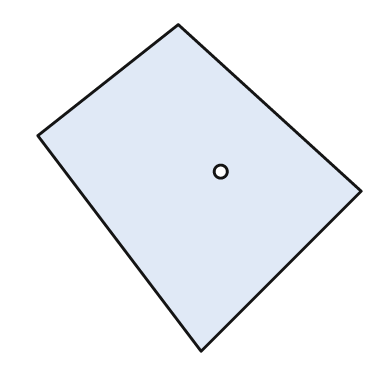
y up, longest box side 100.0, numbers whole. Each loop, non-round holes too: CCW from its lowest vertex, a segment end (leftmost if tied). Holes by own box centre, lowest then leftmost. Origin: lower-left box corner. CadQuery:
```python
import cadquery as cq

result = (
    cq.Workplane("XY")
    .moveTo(50.0, 0.0)
    .lineTo(99.0, 49.0)
    .lineTo(43.0, 100.0)
    .lineTo(0.0, 66.0)
    .close()
    .moveTo(56.0, 55.0)
    .circle(2.0)
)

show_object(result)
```